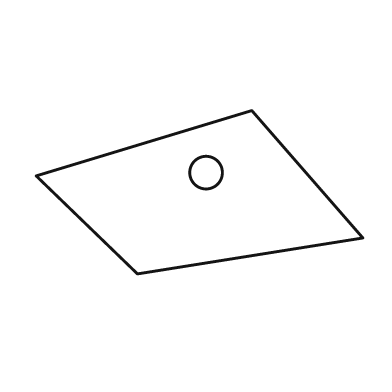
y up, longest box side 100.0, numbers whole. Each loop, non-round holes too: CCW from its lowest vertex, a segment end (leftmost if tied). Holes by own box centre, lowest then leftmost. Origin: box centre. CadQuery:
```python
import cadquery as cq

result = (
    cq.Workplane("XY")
    .moveTo(-19.0, -25.0)
    .lineTo(50.0, -14.0)
    .lineTo(16.0, 25.0)
    .lineTo(-50.0, 5.0)
    .close()
    .moveTo(2.0, 6.0)
    .circle(5.0)
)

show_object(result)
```